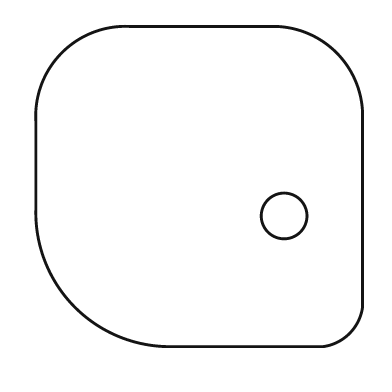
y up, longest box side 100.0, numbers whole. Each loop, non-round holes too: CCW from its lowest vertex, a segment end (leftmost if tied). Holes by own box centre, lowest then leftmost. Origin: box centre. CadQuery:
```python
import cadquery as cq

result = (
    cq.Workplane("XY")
    .moveTo(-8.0, -49.0)
    .lineTo(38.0, -49.0)
    .threePointArc((46.0, -45.0), (50.0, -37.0))
    .lineTo(50.0, 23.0)
    .threePointArc((42.0, 41.0), (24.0, 49.0))
    .lineTo(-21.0, 49.0)
    .threePointArc((-42.0, 41.0), (-50.0, 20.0))
    .lineTo(-50.0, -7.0)
    .threePointArc((-38.0, -37.0), (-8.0, -49.0))
    .close()
    .moveTo(26.0, -9.0)
    .circle(7.0)
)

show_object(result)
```